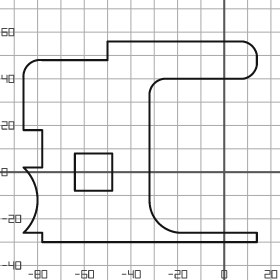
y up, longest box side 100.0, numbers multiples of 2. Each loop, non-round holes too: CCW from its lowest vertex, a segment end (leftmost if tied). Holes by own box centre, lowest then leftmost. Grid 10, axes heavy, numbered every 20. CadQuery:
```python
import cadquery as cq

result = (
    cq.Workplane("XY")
    .moveTo(-78.0, -30.0)
    .lineTo(14.0, -30.0)
    .lineTo(14.0, -26.0)
    .lineTo(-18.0, -26.0)
    .threePointArc((-28.0, -22.0), (-32.0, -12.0))
    .lineTo(-32.0, 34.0)
    .threePointArc((-30.0, 38.0), (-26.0, 40.0))
    .lineTo(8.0, 40.0)
    .threePointArc((12.0, 42.0), (14.0, 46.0))
    .lineTo(14.0, 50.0)
    .threePointArc((12.0, 54.0), (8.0, 56.0))
    .lineTo(-50.0, 56.0)
    .lineTo(-50.0, 48.0)
    .lineTo(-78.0, 48.0)
    .threePointArc((-84.0, 46.0), (-86.0, 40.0))
    .lineTo(-86.0, 18.0)
    .lineTo(-78.0, 18.0)
    .lineTo(-78.0, 2.0)
    .lineTo(-86.0, 2.0)
    .threePointArc((-80.0, -12.0), (-86.0, -26.0))
    .lineTo(-78.0, -26.0)
    .close()
    .moveTo(-64.0, -8.0)
    .lineTo(-48.0, -8.0)
    .lineTo(-48.0, 8.0)
    .lineTo(-64.0, 8.0)
    .close()
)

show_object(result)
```